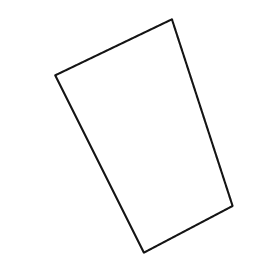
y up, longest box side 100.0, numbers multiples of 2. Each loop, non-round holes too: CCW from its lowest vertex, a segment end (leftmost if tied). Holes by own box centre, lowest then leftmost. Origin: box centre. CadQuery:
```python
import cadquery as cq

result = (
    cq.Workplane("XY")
    .moveTo(0.0, -50.0)
    .lineTo(38.0, -30.0)
    .lineTo(12.0, 50.0)
    .lineTo(-38.0, 26.0)
    .close()
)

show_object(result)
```